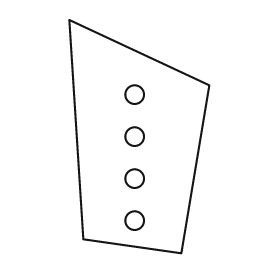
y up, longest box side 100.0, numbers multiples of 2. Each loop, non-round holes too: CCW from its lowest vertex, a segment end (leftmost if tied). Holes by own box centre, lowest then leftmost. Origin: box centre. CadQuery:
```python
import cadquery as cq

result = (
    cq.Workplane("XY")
    .moveTo(18.0, -50.0)
    .lineTo(30.0, 22.0)
    .lineTo(-30.0, 50.0)
    .lineTo(-24.0, -44.0)
    .close()
    .moveTo(-2.0, -36.0)
    .circle(4.0)
    .moveTo(-2.0, -18.0)
    .circle(4.0)
    .moveTo(-2.0, 0.0)
    .circle(4.0)
    .moveTo(-2.0, 18.0)
    .circle(4.0)
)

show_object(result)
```